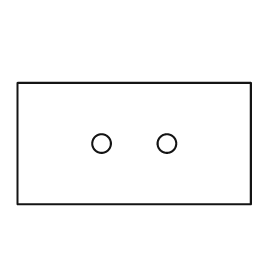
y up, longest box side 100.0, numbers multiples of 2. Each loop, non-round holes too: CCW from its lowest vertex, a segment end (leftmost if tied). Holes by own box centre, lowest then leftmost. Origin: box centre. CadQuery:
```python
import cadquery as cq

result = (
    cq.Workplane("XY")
    .moveTo(-50.0, -26.0)
    .lineTo(50.0, -26.0)
    .lineTo(50.0, 26.0)
    .lineTo(-50.0, 26.0)
    .close()
    .moveTo(-14.0, 0.0)
    .circle(4.0)
    .moveTo(14.0, 0.0)
    .circle(4.0)
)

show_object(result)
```